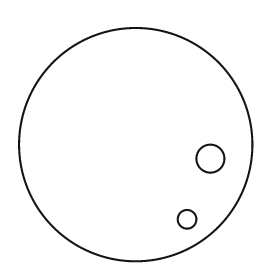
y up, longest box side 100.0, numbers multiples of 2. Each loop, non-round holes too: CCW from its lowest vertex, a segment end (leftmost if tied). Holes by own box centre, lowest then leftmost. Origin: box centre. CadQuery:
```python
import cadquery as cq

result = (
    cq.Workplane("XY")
    .moveTo(0.0, 0.0)
    .circle(50.0)
    .moveTo(22.0, -32.0)
    .circle(4.0)
    .moveTo(32.0, -6.0)
    .circle(6.0)
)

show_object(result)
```